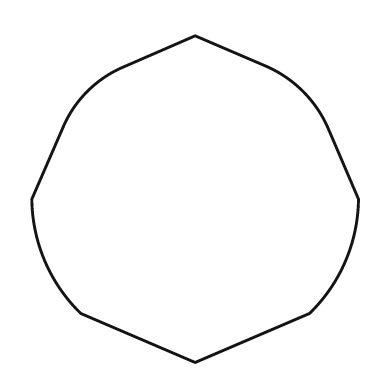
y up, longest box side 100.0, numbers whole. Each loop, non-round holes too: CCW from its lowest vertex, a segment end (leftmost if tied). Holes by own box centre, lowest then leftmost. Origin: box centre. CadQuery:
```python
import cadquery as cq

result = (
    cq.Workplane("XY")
    .moveTo(0.0, -50.0)
    .lineTo(35.0, -35.0)
    .threePointArc((46.0, -19.0), (50.0, 0.0))
    .lineTo(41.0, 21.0)
    .threePointArc((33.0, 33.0), (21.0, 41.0))
    .lineTo(0.0, 50.0)
    .lineTo(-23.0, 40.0)
    .threePointArc((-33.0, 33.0), (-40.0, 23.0))
    .lineTo(-50.0, 0.0)
    .threePointArc((-46.0, -19.0), (-35.0, -35.0))
    .close()
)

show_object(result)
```